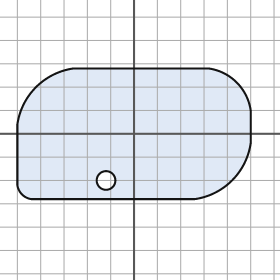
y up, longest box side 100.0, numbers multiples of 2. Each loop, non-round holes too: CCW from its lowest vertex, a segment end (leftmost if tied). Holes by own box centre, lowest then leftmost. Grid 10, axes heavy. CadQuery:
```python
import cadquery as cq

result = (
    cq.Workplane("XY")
    .moveTo(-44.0, -28.0)
    .lineTo(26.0, -28.0)
    .threePointArc((42.0, -20.0), (50.0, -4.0))
    .lineTo(50.0, 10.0)
    .threePointArc((44.0, 22.0), (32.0, 28.0))
    .lineTo(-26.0, 28.0)
    .threePointArc((-42.0, 20.0), (-50.0, 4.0))
    .lineTo(-50.0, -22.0)
    .threePointArc((-48.0, -26.0), (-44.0, -28.0))
    .close()
    .moveTo(-12.0, -20.0)
    .circle(4.0)
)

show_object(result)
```